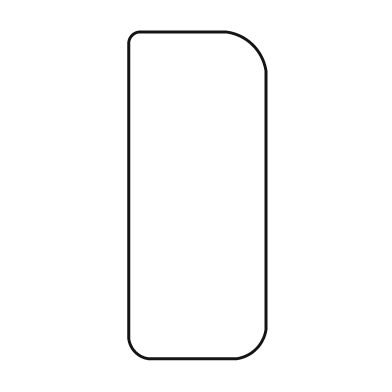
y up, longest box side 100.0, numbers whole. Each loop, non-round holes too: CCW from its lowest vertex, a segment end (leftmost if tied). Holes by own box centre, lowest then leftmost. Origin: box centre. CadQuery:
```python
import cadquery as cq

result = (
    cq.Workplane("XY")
    .moveTo(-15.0, -50.0)
    .lineTo(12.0, -50.0)
    .threePointArc((18.0, -47.0), (21.0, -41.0))
    .lineTo(21.0, 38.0)
    .threePointArc((17.0, 46.0), (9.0, 50.0))
    .lineTo(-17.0, 50.0)
    .threePointArc((-20.0, 49.0), (-21.0, 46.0))
    .lineTo(-21.0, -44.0)
    .threePointArc((-19.0, -48.0), (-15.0, -50.0))
    .close()
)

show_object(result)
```